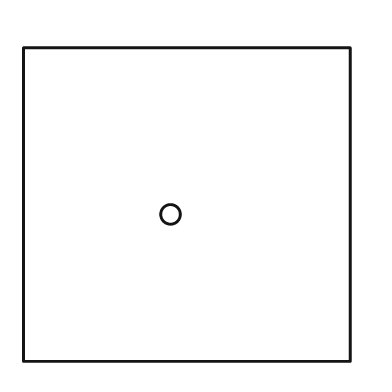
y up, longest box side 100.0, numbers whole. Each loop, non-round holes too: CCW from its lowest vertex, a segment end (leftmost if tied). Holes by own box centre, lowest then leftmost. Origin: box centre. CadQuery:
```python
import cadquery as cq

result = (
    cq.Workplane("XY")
    .moveTo(-50.0, -48.0)
    .lineTo(50.0, -48.0)
    .lineTo(50.0, 48.0)
    .lineTo(-50.0, 48.0)
    .close()
    .moveTo(-5.0, -3.0)
    .circle(3.0)
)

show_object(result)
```